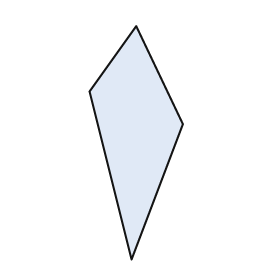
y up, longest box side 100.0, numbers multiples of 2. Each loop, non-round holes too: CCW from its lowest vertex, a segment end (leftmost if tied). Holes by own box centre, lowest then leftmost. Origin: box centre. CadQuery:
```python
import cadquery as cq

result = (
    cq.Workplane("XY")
    .moveTo(-2.0, -50.0)
    .lineTo(20.0, 8.0)
    .lineTo(0.0, 50.0)
    .lineTo(-20.0, 22.0)
    .close()
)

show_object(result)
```